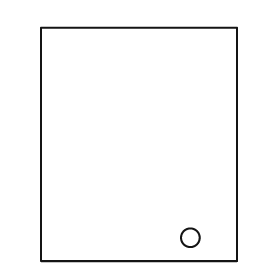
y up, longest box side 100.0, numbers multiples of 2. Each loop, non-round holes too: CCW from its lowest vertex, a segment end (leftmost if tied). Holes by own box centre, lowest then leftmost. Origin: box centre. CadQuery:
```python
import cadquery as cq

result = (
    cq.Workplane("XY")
    .moveTo(-42.0, -50.0)
    .lineTo(42.0, -50.0)
    .lineTo(42.0, 50.0)
    .lineTo(-42.0, 50.0)
    .close()
    .moveTo(22.0, -40.0)
    .circle(4.0)
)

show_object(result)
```